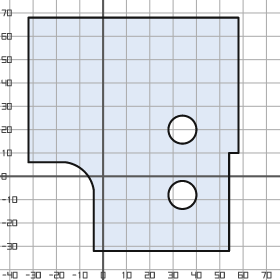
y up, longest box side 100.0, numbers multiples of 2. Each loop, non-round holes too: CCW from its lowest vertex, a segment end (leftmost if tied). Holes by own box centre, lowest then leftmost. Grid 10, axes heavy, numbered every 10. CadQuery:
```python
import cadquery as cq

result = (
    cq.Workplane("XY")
    .moveTo(-4.0, -32.0)
    .lineTo(54.0, -32.0)
    .lineTo(54.0, 10.0)
    .lineTo(58.0, 10.0)
    .lineTo(58.0, 68.0)
    .lineTo(-32.0, 68.0)
    .lineTo(-32.0, 6.0)
    .lineTo(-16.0, 6.0)
    .threePointArc((-8.0, 2.0), (-4.0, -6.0))
    .close()
    .moveTo(34.0, -8.0)
    .circle(6.0)
    .moveTo(34.0, 20.0)
    .circle(6.0)
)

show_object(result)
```